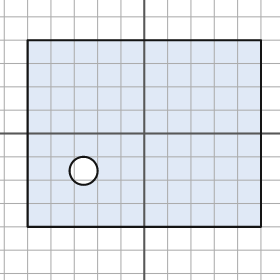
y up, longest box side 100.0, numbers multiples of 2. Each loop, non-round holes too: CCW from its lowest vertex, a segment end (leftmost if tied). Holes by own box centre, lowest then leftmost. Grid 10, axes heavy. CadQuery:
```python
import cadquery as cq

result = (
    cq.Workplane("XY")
    .moveTo(-50.0, -40.0)
    .lineTo(50.0, -40.0)
    .lineTo(50.0, 40.0)
    .lineTo(-50.0, 40.0)
    .close()
    .moveTo(-26.0, -16.0)
    .circle(6.0)
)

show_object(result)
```